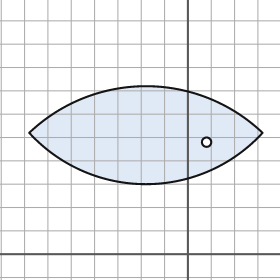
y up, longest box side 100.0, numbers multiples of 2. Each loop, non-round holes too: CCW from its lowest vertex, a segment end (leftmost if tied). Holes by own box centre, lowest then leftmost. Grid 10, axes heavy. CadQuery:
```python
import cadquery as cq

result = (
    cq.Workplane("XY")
    .moveTo(-68.0, 52.0)
    .threePointArc((-18.0, 30.0), (32.0, 52.0))
    .threePointArc((-18.0, 72.0), (-68.0, 52.0))
    .close()
    .moveTo(8.0, 48.0)
    .circle(2.0)
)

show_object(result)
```